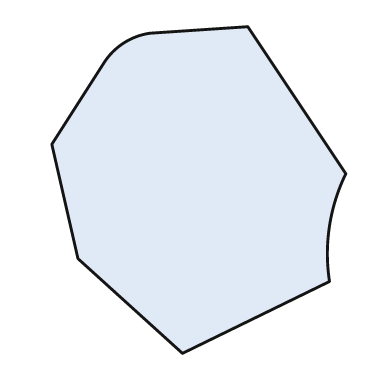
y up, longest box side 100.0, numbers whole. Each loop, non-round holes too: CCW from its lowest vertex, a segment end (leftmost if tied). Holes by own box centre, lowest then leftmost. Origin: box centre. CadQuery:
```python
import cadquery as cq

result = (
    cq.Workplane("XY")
    .moveTo(-5.0, -50.0)
    .lineTo(40.0, -28.0)
    .threePointArc((40.0, -11.0), (45.0, 5.0))
    .lineTo(15.0, 50.0)
    .lineTo(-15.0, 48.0)
    .threePointArc((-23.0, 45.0), (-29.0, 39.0))
    .lineTo(-45.0, 14.0)
    .lineTo(-37.0, -21.0)
    .close()
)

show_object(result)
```